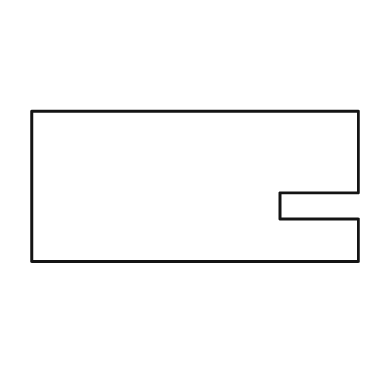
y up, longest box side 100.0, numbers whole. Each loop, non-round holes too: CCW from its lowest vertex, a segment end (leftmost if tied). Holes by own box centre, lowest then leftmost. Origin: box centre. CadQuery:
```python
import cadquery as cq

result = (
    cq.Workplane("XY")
    .moveTo(-50.0, -23.0)
    .lineTo(50.0, -23.0)
    .lineTo(50.0, -10.0)
    .lineTo(26.0, -10.0)
    .lineTo(26.0, -2.0)
    .lineTo(50.0, -2.0)
    .lineTo(50.0, 23.0)
    .lineTo(-50.0, 23.0)
    .close()
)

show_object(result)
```